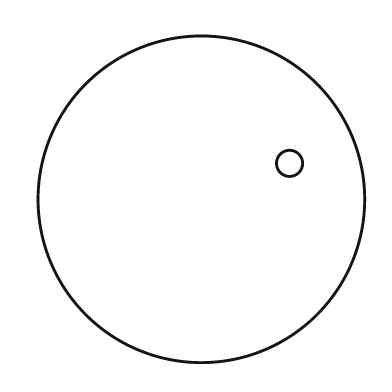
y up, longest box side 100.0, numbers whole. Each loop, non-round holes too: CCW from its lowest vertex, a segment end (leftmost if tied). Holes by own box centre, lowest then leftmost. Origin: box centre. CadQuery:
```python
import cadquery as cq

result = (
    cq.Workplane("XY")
    .moveTo(0.0, 0.0)
    .circle(50.0)
    .moveTo(27.0, 11.0)
    .circle(4.0)
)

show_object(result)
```